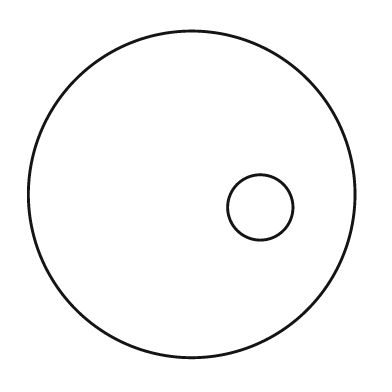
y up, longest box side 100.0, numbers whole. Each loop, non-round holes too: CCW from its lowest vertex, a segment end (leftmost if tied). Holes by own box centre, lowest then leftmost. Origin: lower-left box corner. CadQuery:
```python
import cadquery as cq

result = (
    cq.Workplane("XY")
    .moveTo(50.0, 50.0)
    .circle(50.0)
    .moveTo(71.0, 46.0)
    .circle(10.0)
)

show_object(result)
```